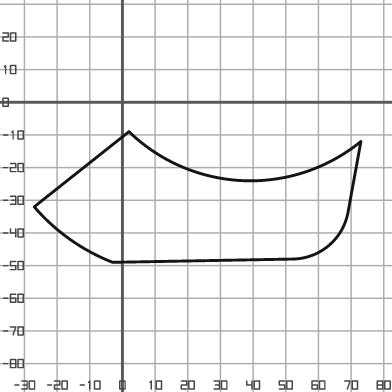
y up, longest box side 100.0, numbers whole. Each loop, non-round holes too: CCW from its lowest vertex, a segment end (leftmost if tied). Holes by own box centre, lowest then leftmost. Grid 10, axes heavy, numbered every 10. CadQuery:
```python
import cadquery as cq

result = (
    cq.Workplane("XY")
    .moveTo(-3.0, -49.0)
    .lineTo(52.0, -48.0)
    .threePointArc((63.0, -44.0), (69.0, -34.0))
    .lineTo(73.0, -12.0)
    .threePointArc((37.0, -24.0), (2.0, -9.0))
    .lineTo(-27.0, -32.0)
    .threePointArc((-16.0, -42.0), (-3.0, -49.0))
    .close()
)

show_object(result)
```